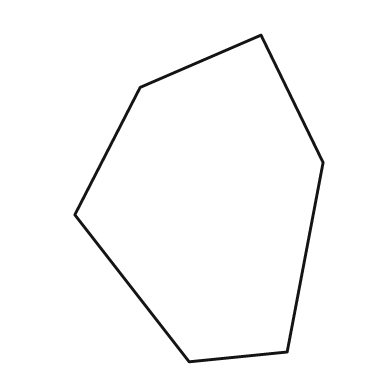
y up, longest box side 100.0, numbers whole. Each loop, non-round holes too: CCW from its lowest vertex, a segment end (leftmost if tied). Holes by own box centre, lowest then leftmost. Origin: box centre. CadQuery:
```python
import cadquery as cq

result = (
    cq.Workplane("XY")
    .moveTo(-3.0, -50.0)
    .lineTo(27.0, -47.0)
    .lineTo(38.0, 11.0)
    .lineTo(19.0, 50.0)
    .lineTo(-18.0, 34.0)
    .lineTo(-38.0, -5.0)
    .close()
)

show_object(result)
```